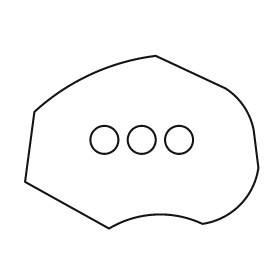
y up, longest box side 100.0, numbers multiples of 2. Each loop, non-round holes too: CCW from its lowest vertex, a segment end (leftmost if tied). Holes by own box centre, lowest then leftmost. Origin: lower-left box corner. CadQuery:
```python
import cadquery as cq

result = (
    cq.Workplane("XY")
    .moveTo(36.0, 0.0)
    .threePointArc((56.0, 6.0), (76.0, 2.0))
    .threePointArc((92.0, 10.0), (100.0, 26.0))
    .lineTo(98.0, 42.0)
    .threePointArc((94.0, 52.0), (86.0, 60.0))
    .lineTo(56.0, 74.0)
    .threePointArc((28.0, 66.0), (4.0, 50.0))
    .lineTo(0.0, 20.0)
    .close()
    .moveTo(34.0, 38.0)
    .circle(6.0)
    .moveTo(50.0, 38.0)
    .circle(6.0)
    .moveTo(66.0, 38.0)
    .circle(6.0)
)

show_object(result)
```